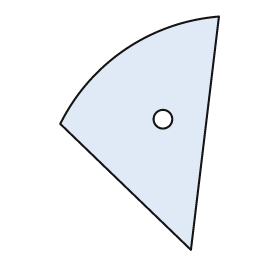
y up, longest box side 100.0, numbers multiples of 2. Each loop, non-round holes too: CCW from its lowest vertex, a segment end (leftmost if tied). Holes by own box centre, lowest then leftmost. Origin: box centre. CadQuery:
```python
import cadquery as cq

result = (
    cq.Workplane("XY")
    .moveTo(22.0, -50.0)
    .lineTo(34.0, 50.0)
    .threePointArc((-6.0, 36.0), (-34.0, 4.0))
    .close()
    .moveTo(10.0, 6.0)
    .circle(4.0)
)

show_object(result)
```